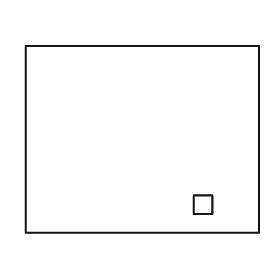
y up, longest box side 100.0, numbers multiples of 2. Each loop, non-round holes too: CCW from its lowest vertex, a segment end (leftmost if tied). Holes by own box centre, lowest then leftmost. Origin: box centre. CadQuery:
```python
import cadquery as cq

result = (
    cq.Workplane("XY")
    .moveTo(-50.0, -40.0)
    .lineTo(50.0, -40.0)
    .lineTo(50.0, 40.0)
    .lineTo(-50.0, 40.0)
    .close()
    .moveTo(22.0, -32.0)
    .lineTo(30.0, -32.0)
    .lineTo(30.0, -24.0)
    .lineTo(22.0, -24.0)
    .close()
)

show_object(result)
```